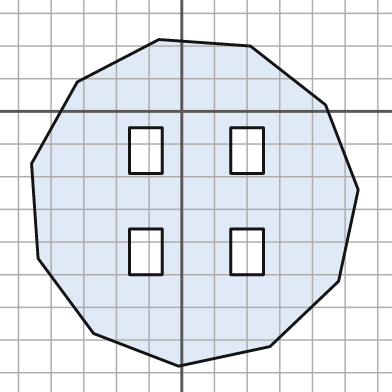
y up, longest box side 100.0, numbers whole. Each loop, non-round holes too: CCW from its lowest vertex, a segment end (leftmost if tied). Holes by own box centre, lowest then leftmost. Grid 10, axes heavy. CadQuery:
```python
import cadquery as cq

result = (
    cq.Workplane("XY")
    .moveTo(-1.0, -78.0)
    .lineTo(27.0, -72.0)
    .lineTo(48.0, -52.0)
    .lineTo(54.0, -24.0)
    .lineTo(44.0, 2.0)
    .lineTo(21.0, 20.0)
    .lineTo(-7.0, 22.0)
    .lineTo(-32.0, 9.0)
    .lineTo(-46.0, -16.0)
    .lineTo(-44.0, -45.0)
    .lineTo(-27.0, -68.0)
    .close()
    .moveTo(-16.0, -50.0)
    .lineTo(-6.0, -50.0)
    .lineTo(-6.0, -36.0)
    .lineTo(-16.0, -36.0)
    .close()
    .moveTo(15.0, -50.0)
    .lineTo(25.0, -50.0)
    .lineTo(25.0, -36.0)
    .lineTo(15.0, -36.0)
    .close()
    .moveTo(-16.0, -19.0)
    .lineTo(-6.0, -19.0)
    .lineTo(-6.0, -5.0)
    .lineTo(-16.0, -5.0)
    .close()
    .moveTo(15.0, -19.0)
    .lineTo(25.0, -19.0)
    .lineTo(25.0, -5.0)
    .lineTo(15.0, -5.0)
    .close()
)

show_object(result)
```